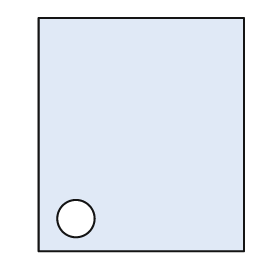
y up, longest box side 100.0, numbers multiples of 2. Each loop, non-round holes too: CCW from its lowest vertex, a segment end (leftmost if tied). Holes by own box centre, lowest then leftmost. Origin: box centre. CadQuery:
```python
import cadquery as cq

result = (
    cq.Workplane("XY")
    .moveTo(-44.0, -50.0)
    .lineTo(44.0, -50.0)
    .lineTo(44.0, 50.0)
    .lineTo(-44.0, 50.0)
    .close()
    .moveTo(-28.0, -36.0)
    .circle(8.0)
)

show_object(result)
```